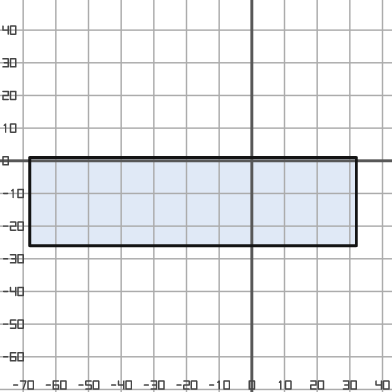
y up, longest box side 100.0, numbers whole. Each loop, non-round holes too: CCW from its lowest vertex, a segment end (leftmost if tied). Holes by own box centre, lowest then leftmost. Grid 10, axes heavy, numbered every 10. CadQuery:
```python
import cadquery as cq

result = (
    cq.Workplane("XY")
    .moveTo(-68.0, -26.0)
    .lineTo(32.0, -26.0)
    .lineTo(32.0, 1.0)
    .lineTo(-68.0, 1.0)
    .close()
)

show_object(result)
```